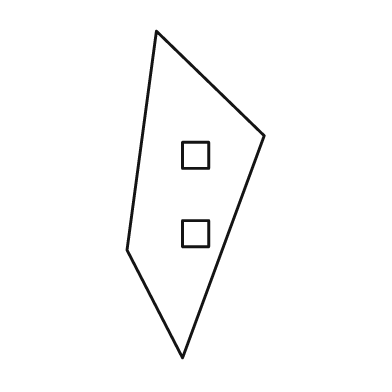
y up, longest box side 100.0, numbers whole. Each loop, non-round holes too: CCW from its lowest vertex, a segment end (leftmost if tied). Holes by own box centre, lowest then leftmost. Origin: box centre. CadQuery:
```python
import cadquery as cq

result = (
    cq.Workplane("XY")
    .moveTo(-4.0, -50.0)
    .lineTo(21.0, 18.0)
    .lineTo(-12.0, 50.0)
    .lineTo(-21.0, -17.0)
    .close()
    .moveTo(-4.0, -16.0)
    .lineTo(4.0, -16.0)
    .lineTo(4.0, -8.0)
    .lineTo(-4.0, -8.0)
    .close()
    .moveTo(-4.0, 8.0)
    .lineTo(4.0, 8.0)
    .lineTo(4.0, 16.0)
    .lineTo(-4.0, 16.0)
    .close()
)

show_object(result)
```